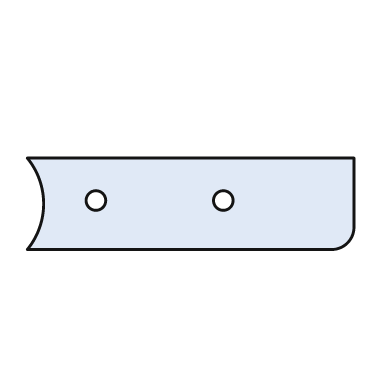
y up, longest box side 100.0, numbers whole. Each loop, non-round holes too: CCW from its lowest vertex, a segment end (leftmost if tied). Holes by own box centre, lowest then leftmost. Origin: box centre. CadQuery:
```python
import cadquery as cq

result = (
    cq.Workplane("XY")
    .moveTo(-50.0, -14.0)
    .lineTo(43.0, -14.0)
    .threePointArc((48.0, -12.0), (50.0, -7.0))
    .lineTo(50.0, 14.0)
    .lineTo(-50.0, 14.0)
    .threePointArc((-45.0, 0.0), (-50.0, -14.0))
    .close()
    .moveTo(-29.0, 1.0)
    .circle(3.0)
    .moveTo(10.0, 1.0)
    .circle(3.0)
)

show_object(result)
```